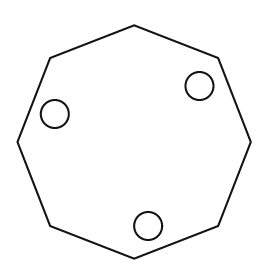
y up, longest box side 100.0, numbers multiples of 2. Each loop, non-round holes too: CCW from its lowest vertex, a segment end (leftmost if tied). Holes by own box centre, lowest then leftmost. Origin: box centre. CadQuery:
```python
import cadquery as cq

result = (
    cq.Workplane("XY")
    .moveTo(0.0, -50.0)
    .lineTo(36.0, -36.0)
    .lineTo(50.0, 0.0)
    .lineTo(36.0, 36.0)
    .lineTo(0.0, 50.0)
    .lineTo(-36.0, 36.0)
    .lineTo(-50.0, 0.0)
    .lineTo(-36.0, -36.0)
    .close()
    .moveTo(6.0, -36.0)
    .circle(6.0)
    .moveTo(-34.0, 12.0)
    .circle(6.0)
    .moveTo(28.0, 24.0)
    .circle(6.0)
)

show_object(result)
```